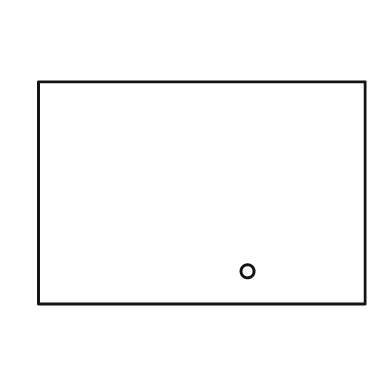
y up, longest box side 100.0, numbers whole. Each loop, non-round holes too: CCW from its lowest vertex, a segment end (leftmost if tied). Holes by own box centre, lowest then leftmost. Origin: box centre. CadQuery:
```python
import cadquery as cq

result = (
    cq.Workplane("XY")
    .moveTo(-50.0, -34.0)
    .lineTo(50.0, -34.0)
    .lineTo(50.0, 34.0)
    .lineTo(-50.0, 34.0)
    .close()
    .moveTo(14.0, -24.0)
    .circle(2.0)
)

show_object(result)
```